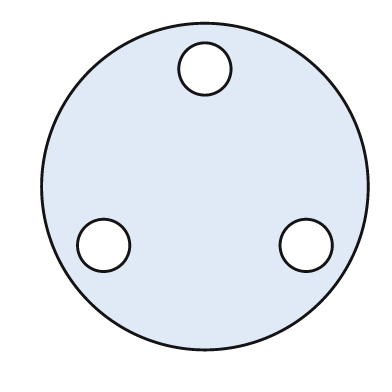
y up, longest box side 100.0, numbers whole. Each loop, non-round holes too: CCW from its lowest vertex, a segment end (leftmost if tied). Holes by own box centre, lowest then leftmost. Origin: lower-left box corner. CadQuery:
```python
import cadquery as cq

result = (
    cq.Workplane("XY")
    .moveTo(50.0, 50.0)
    .circle(50.0)
    .moveTo(19.0, 32.0)
    .circle(8.0)
    .moveTo(81.0, 32.0)
    .circle(8.0)
    .moveTo(50.0, 86.0)
    .circle(8.0)
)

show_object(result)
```